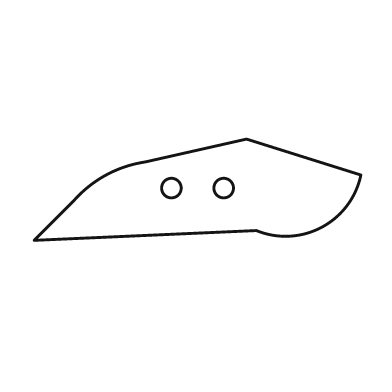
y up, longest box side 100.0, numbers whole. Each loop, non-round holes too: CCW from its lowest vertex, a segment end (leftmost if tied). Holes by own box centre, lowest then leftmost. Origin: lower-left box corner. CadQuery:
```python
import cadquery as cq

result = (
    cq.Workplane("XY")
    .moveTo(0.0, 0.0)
    .lineTo(68.0, 3.0)
    .threePointArc((88.0, 4.0), (100.0, 20.0))
    .lineTo(65.0, 31.0)
    .lineTo(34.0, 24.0)
    .threePointArc((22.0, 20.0), (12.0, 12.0))
    .close()
    .moveTo(42.0, 16.0)
    .circle(3.0)
    .moveTo(58.0, 16.0)
    .circle(3.0)
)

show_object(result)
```